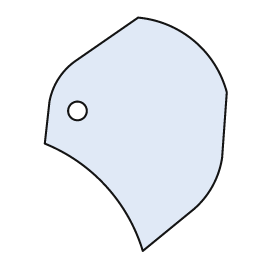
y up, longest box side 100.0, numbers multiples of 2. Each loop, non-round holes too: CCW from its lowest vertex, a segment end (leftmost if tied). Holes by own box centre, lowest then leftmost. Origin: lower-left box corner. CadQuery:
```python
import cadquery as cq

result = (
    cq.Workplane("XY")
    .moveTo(42.0, 0.0)
    .lineTo(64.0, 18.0)
    .threePointArc((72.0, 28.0), (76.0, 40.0))
    .lineTo(78.0, 68.0)
    .threePointArc((64.0, 90.0), (40.0, 100.0))
    .lineTo(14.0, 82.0)
    .threePointArc((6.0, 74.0), (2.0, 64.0))
    .lineTo(0.0, 46.0)
    .threePointArc((26.0, 28.0), (42.0, 0.0))
    .close()
    .moveTo(14.0, 60.0)
    .circle(4.0)
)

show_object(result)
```